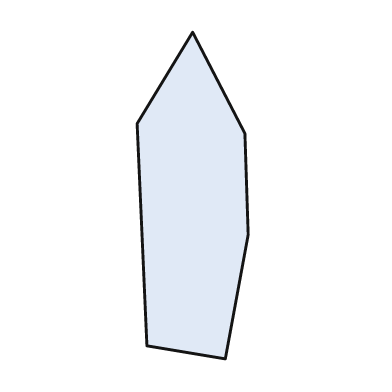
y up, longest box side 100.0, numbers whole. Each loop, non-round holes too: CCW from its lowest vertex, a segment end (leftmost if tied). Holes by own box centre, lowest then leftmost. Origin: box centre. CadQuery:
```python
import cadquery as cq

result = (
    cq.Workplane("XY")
    .moveTo(10.0, -50.0)
    .lineTo(17.0, -12.0)
    .lineTo(16.0, 19.0)
    .lineTo(0.0, 50.0)
    .lineTo(-17.0, 22.0)
    .lineTo(-14.0, -46.0)
    .close()
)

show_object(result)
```